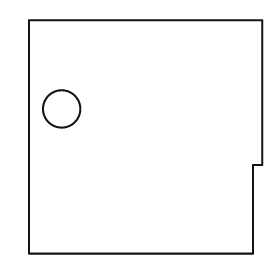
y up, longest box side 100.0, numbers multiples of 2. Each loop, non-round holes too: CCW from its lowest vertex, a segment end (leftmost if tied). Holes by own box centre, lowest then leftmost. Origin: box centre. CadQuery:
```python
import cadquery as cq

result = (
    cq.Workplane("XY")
    .moveTo(-50.0, -50.0)
    .lineTo(46.0, -50.0)
    .lineTo(46.0, -12.0)
    .lineTo(50.0, -12.0)
    .lineTo(50.0, 50.0)
    .lineTo(-50.0, 50.0)
    .close()
    .moveTo(-36.0, 12.0)
    .circle(8.0)
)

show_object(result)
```